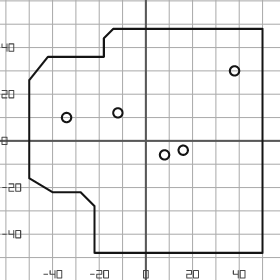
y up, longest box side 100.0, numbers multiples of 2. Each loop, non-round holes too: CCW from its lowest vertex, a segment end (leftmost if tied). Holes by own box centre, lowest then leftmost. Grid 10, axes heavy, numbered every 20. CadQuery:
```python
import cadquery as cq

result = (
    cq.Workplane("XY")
    .moveTo(-22.0, -48.0)
    .lineTo(50.0, -48.0)
    .lineTo(50.0, 48.0)
    .lineTo(-14.0, 48.0)
    .lineTo(-18.0, 44.0)
    .lineTo(-18.0, 36.0)
    .lineTo(-42.0, 36.0)
    .lineTo(-50.0, 26.0)
    .lineTo(-50.0, -16.0)
    .lineTo(-40.0, -22.0)
    .lineTo(-28.0, -22.0)
    .lineTo(-22.0, -28.0)
    .close()
    .moveTo(8.0, -6.0)
    .circle(2.0)
    .moveTo(16.0, -4.0)
    .circle(2.0)
    .moveTo(-34.0, 10.0)
    .circle(2.0)
    .moveTo(-12.0, 12.0)
    .circle(2.0)
    .moveTo(38.0, 30.0)
    .circle(2.0)
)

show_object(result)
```